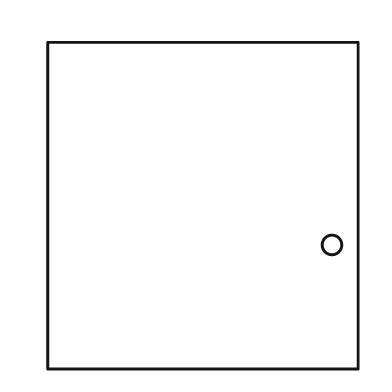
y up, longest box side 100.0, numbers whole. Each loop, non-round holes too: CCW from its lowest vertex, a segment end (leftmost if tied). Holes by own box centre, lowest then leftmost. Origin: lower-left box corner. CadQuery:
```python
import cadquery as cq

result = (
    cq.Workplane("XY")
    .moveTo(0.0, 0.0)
    .lineTo(95.0, 0.0)
    .lineTo(95.0, 100.0)
    .lineTo(0.0, 100.0)
    .close()
    .moveTo(87.0, 38.0)
    .circle(3.0)
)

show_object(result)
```